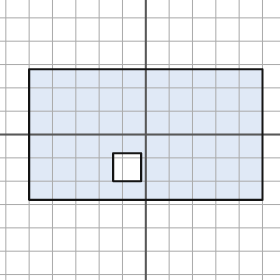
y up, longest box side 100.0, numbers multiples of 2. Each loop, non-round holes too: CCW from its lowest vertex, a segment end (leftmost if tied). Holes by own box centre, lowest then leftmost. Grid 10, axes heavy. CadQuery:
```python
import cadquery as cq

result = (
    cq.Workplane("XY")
    .moveTo(-50.0, -28.0)
    .lineTo(50.0, -28.0)
    .lineTo(50.0, 28.0)
    .lineTo(-50.0, 28.0)
    .close()
    .moveTo(-14.0, -20.0)
    .lineTo(-2.0, -20.0)
    .lineTo(-2.0, -8.0)
    .lineTo(-14.0, -8.0)
    .close()
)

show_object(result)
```